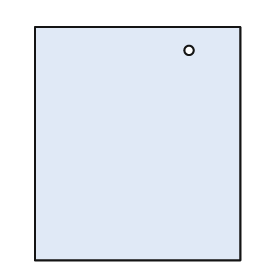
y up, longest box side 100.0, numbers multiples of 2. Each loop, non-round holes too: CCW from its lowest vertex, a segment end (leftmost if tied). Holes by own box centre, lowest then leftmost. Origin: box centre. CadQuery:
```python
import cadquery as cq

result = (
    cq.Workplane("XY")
    .moveTo(-44.0, -50.0)
    .lineTo(44.0, -50.0)
    .lineTo(44.0, 50.0)
    .lineTo(-44.0, 50.0)
    .close()
    .moveTo(22.0, 40.0)
    .circle(2.0)
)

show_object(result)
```